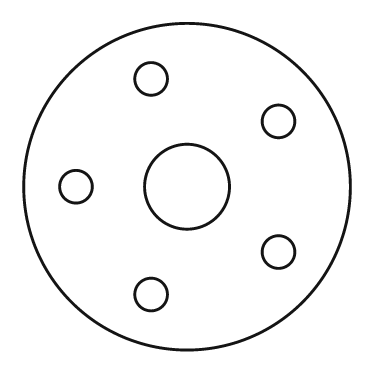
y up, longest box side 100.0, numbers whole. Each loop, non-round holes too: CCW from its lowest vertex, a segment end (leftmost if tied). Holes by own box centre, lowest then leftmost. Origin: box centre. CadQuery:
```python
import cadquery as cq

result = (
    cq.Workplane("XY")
    .moveTo(0.0, 0.0)
    .circle(50.0)
    .moveTo(-11.0, -33.0)
    .circle(5.0)
    .moveTo(28.0, -20.0)
    .circle(5.0)
    .moveTo(-34.0, 0.0)
    .circle(5.0)
    .moveTo(0.0, 0.0)
    .circle(13.0)
    .moveTo(28.0, 20.0)
    .circle(5.0)
    .moveTo(-11.0, 33.0)
    .circle(5.0)
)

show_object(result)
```